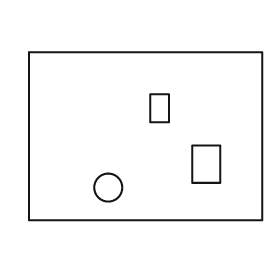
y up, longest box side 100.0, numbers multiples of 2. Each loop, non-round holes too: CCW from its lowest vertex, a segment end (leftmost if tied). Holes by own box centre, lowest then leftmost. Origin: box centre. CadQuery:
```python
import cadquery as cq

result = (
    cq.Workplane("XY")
    .moveTo(-50.0, -36.0)
    .lineTo(50.0, -36.0)
    .lineTo(50.0, 36.0)
    .lineTo(-50.0, 36.0)
    .close()
    .moveTo(-16.0, -22.0)
    .circle(6.0)
    .moveTo(20.0, -20.0)
    .lineTo(32.0, -20.0)
    .lineTo(32.0, -4.0)
    .lineTo(20.0, -4.0)
    .close()
    .moveTo(2.0, 6.0)
    .lineTo(10.0, 6.0)
    .lineTo(10.0, 18.0)
    .lineTo(2.0, 18.0)
    .close()
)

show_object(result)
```